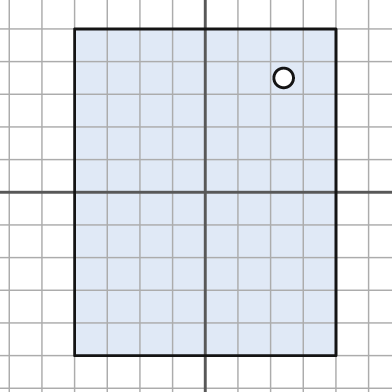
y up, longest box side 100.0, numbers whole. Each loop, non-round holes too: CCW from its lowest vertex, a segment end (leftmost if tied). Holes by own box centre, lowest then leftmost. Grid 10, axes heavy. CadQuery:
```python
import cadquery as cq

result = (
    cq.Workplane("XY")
    .moveTo(-40.0, -50.0)
    .lineTo(40.0, -50.0)
    .lineTo(40.0, 50.0)
    .lineTo(-40.0, 50.0)
    .close()
    .moveTo(24.0, 35.0)
    .circle(3.0)
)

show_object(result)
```